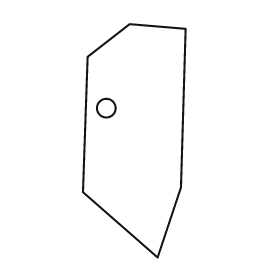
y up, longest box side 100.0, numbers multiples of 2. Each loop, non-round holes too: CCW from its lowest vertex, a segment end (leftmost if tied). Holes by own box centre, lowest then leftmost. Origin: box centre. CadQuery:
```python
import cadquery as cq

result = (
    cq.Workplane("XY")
    .moveTo(10.0, -50.0)
    .lineTo(20.0, -20.0)
    .lineTo(22.0, 48.0)
    .lineTo(-2.0, 50.0)
    .lineTo(-20.0, 36.0)
    .lineTo(-22.0, -22.0)
    .close()
    .moveTo(-12.0, 14.0)
    .circle(4.0)
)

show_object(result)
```